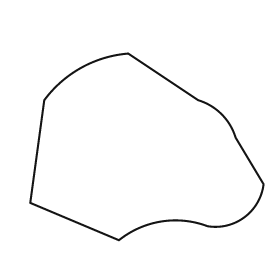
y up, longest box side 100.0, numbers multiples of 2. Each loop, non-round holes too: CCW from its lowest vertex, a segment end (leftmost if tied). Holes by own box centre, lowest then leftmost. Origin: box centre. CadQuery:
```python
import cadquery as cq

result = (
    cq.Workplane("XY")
    .moveTo(-12.0, -40.0)
    .threePointArc((6.0, -32.0), (26.0, -34.0))
    .threePointArc((42.0, -30.0), (50.0, -16.0))
    .lineTo(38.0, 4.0)
    .threePointArc((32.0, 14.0), (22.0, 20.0))
    .lineTo(-8.0, 40.0)
    .threePointArc((-28.0, 34.0), (-44.0, 20.0))
    .lineTo(-50.0, -24.0)
    .close()
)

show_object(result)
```